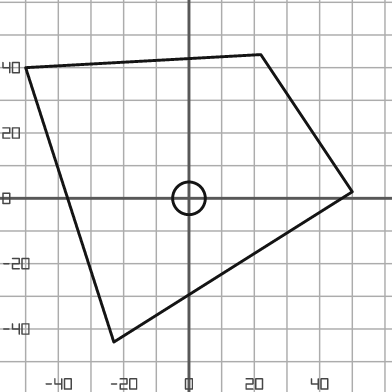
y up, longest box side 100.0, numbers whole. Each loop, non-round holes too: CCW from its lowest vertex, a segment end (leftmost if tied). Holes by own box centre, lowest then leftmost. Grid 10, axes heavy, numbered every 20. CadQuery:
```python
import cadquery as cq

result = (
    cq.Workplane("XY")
    .moveTo(-23.0, -44.0)
    .lineTo(50.0, 2.0)
    .lineTo(22.0, 44.0)
    .lineTo(-50.0, 40.0)
    .close()
    .moveTo(0.0, 0.0)
    .circle(5.0)
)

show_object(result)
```